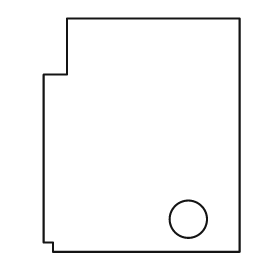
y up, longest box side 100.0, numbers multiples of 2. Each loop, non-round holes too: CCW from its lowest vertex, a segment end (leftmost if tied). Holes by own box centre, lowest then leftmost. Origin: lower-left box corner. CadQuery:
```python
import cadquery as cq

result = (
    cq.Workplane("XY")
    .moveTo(4.0, 0.0)
    .lineTo(84.0, 0.0)
    .lineTo(84.0, 100.0)
    .lineTo(10.0, 100.0)
    .lineTo(10.0, 76.0)
    .lineTo(0.0, 76.0)
    .lineTo(0.0, 4.0)
    .lineTo(4.0, 4.0)
    .close()
    .moveTo(62.0, 14.0)
    .circle(8.0)
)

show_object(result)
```